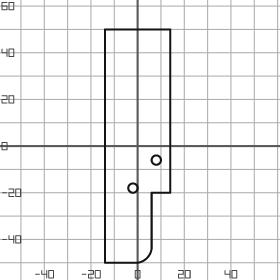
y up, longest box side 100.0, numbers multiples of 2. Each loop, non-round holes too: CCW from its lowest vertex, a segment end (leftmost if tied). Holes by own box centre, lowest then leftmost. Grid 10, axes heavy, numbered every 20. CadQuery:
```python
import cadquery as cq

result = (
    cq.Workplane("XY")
    .moveTo(-14.0, -50.0)
    .lineTo(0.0, -50.0)
    .threePointArc((4.0, -48.0), (6.0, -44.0))
    .lineTo(6.0, -20.0)
    .lineTo(14.0, -20.0)
    .lineTo(14.0, 50.0)
    .lineTo(-14.0, 50.0)
    .close()
    .moveTo(-2.0, -18.0)
    .circle(2.0)
    .moveTo(8.0, -6.0)
    .circle(2.0)
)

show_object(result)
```